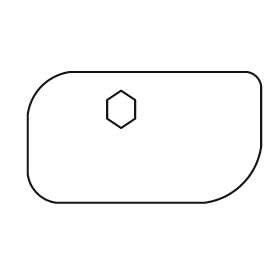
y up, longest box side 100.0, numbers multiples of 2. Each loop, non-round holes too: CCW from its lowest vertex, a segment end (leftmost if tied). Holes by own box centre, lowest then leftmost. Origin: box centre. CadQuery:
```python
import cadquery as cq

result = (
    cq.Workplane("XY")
    .moveTo(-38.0, -28.0)
    .lineTo(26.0, -28.0)
    .threePointArc((42.0, -20.0), (50.0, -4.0))
    .lineTo(50.0, 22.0)
    .threePointArc((48.0, 26.0), (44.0, 28.0))
    .lineTo(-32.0, 28.0)
    .threePointArc((-44.0, 22.0), (-50.0, 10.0))
    .lineTo(-50.0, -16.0)
    .threePointArc((-46.0, -24.0), (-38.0, -28.0))
    .close()
    .moveTo(-10.0, 4.0)
    .lineTo(-4.0, 8.0)
    .lineTo(-4.0, 16.0)
    .lineTo(-10.0, 20.0)
    .lineTo(-16.0, 16.0)
    .lineTo(-16.0, 8.0)
    .close()
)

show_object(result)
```